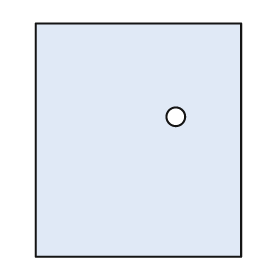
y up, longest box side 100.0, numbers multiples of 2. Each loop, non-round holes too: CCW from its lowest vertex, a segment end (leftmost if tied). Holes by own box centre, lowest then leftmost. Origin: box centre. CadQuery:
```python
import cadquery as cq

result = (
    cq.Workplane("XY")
    .moveTo(-44.0, -50.0)
    .lineTo(44.0, -50.0)
    .lineTo(44.0, 50.0)
    .lineTo(-44.0, 50.0)
    .close()
    .moveTo(16.0, 10.0)
    .circle(4.0)
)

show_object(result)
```